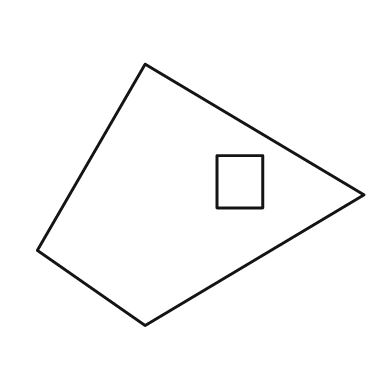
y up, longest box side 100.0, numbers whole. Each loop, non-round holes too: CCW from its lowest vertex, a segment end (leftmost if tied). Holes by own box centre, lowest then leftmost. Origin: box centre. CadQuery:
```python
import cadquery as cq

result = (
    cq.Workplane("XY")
    .moveTo(-17.0, -40.0)
    .lineTo(50.0, 0.0)
    .lineTo(-17.0, 40.0)
    .lineTo(-50.0, -17.0)
    .close()
    .moveTo(5.0, -4.0)
    .lineTo(19.0, -4.0)
    .lineTo(19.0, 12.0)
    .lineTo(5.0, 12.0)
    .close()
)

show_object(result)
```